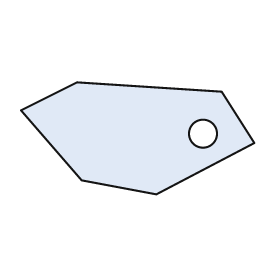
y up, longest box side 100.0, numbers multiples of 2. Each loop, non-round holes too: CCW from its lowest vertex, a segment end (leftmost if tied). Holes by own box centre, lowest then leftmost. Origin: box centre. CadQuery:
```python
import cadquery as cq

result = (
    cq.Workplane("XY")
    .moveTo(8.0, -24.0)
    .lineTo(50.0, -2.0)
    .lineTo(36.0, 20.0)
    .lineTo(-26.0, 24.0)
    .lineTo(-50.0, 12.0)
    .lineTo(-24.0, -18.0)
    .close()
    .moveTo(28.0, 2.0)
    .circle(6.0)
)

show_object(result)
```